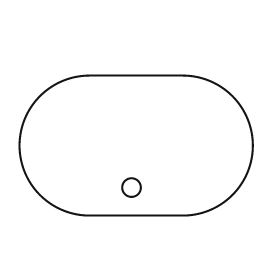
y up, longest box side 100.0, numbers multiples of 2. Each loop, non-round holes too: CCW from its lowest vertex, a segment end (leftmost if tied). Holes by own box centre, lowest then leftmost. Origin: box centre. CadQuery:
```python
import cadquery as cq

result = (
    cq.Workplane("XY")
    .moveTo(-20.0, -30.0)
    .lineTo(20.0, -30.0)
    .threePointArc((50.0, 0.0), (20.0, 30.0))
    .lineTo(-20.0, 30.0)
    .threePointArc((-50.0, 0.0), (-20.0, -30.0))
    .close()
    .moveTo(-2.0, -18.0)
    .circle(4.0)
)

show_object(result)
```